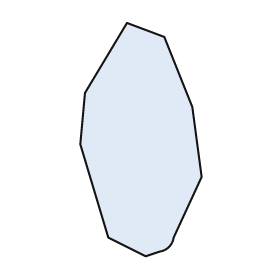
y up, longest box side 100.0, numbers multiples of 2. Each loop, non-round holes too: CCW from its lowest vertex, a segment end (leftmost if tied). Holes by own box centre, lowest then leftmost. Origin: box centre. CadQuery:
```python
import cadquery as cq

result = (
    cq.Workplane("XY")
    .moveTo(2.0, -50.0)
    .lineTo(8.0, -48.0)
    .threePointArc((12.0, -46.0), (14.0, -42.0))
    .lineTo(26.0, -16.0)
    .lineTo(22.0, 14.0)
    .lineTo(10.0, 44.0)
    .lineTo(-6.0, 50.0)
    .lineTo(-24.0, 20.0)
    .lineTo(-26.0, -2.0)
    .lineTo(-14.0, -42.0)
    .close()
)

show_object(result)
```